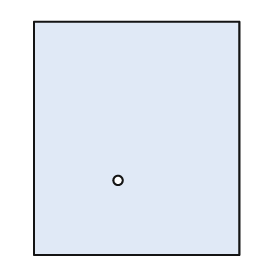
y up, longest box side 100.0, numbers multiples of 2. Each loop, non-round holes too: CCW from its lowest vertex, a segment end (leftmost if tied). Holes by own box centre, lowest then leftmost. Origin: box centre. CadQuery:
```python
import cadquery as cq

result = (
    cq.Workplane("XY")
    .moveTo(-44.0, -50.0)
    .lineTo(44.0, -50.0)
    .lineTo(44.0, 50.0)
    .lineTo(-44.0, 50.0)
    .close()
    .moveTo(-8.0, -18.0)
    .circle(2.0)
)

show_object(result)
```